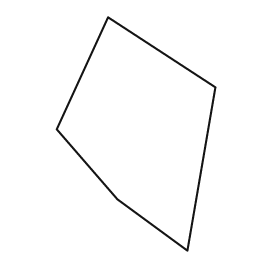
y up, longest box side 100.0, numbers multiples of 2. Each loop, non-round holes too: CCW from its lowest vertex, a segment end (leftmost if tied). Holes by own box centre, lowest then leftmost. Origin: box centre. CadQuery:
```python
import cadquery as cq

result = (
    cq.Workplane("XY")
    .moveTo(22.0, -50.0)
    .lineTo(34.0, 20.0)
    .lineTo(-12.0, 50.0)
    .lineTo(-34.0, 2.0)
    .lineTo(-8.0, -28.0)
    .close()
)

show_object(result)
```